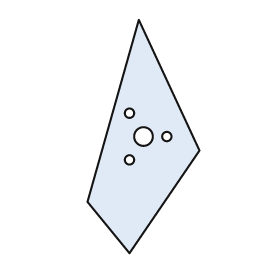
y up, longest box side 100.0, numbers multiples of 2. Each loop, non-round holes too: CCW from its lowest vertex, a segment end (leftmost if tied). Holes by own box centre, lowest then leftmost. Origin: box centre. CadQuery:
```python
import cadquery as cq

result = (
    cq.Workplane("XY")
    .moveTo(-6.0, -50.0)
    .lineTo(24.0, -6.0)
    .lineTo(-2.0, 50.0)
    .lineTo(-24.0, -28.0)
    .close()
    .moveTo(-6.0, -10.0)
    .circle(2.0)
    .moveTo(0.0, 0.0)
    .circle(4.0)
    .moveTo(10.0, 0.0)
    .circle(2.0)
    .moveTo(-6.0, 10.0)
    .circle(2.0)
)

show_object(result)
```